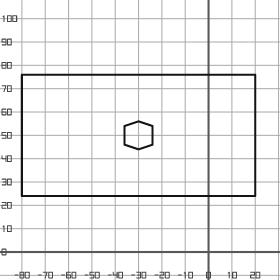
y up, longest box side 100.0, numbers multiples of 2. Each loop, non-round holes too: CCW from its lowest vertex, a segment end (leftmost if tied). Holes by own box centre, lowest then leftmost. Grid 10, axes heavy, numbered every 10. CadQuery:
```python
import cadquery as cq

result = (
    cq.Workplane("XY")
    .moveTo(-80.0, 24.0)
    .lineTo(20.0, 24.0)
    .lineTo(20.0, 76.0)
    .lineTo(-80.0, 76.0)
    .close()
    .moveTo(-30.0, 44.0)
    .lineTo(-24.0, 46.0)
    .lineTo(-24.0, 54.0)
    .lineTo(-30.0, 56.0)
    .lineTo(-36.0, 54.0)
    .lineTo(-36.0, 46.0)
    .close()
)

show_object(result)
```